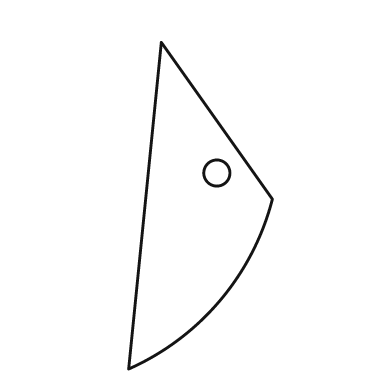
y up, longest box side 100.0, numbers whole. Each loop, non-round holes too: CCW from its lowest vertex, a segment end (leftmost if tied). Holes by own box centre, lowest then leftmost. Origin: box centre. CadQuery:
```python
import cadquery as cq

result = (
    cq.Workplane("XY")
    .moveTo(-22.0, -50.0)
    .threePointArc((6.0, -29.0), (22.0, 2.0))
    .lineTo(-12.0, 50.0)
    .close()
    .moveTo(5.0, 10.0)
    .circle(4.0)
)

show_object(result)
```